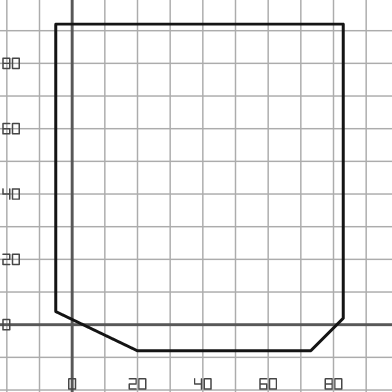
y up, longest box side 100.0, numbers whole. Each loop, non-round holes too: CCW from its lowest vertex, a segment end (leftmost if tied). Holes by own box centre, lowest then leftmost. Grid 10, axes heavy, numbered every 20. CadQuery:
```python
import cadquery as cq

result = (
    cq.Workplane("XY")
    .moveTo(20.0, -8.0)
    .lineTo(73.0, -8.0)
    .lineTo(83.0, 2.0)
    .lineTo(83.0, 92.0)
    .lineTo(-5.0, 92.0)
    .lineTo(-5.0, 4.0)
    .close()
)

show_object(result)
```